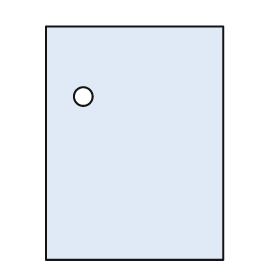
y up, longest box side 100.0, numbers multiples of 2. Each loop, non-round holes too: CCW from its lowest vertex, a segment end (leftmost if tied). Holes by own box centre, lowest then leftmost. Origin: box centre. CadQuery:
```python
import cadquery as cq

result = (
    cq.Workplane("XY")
    .moveTo(-38.0, -50.0)
    .lineTo(38.0, -50.0)
    .lineTo(38.0, 50.0)
    .lineTo(-38.0, 50.0)
    .close()
    .moveTo(-22.0, 20.0)
    .circle(4.0)
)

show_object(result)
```